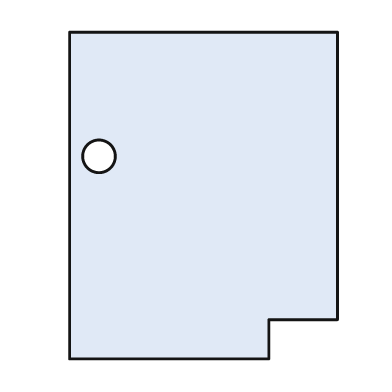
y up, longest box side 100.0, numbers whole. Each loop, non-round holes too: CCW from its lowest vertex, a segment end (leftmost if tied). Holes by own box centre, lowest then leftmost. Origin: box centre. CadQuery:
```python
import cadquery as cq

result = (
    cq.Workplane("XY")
    .moveTo(-41.0, -50.0)
    .lineTo(20.0, -50.0)
    .lineTo(20.0, -38.0)
    .lineTo(41.0, -38.0)
    .lineTo(41.0, 50.0)
    .lineTo(-41.0, 50.0)
    .close()
    .moveTo(-32.0, 12.0)
    .circle(5.0)
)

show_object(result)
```